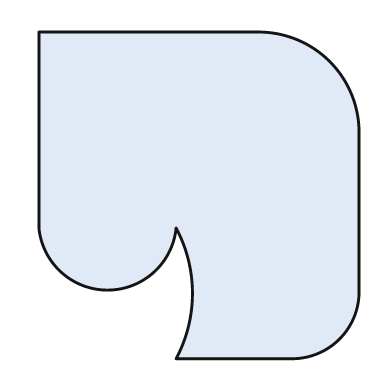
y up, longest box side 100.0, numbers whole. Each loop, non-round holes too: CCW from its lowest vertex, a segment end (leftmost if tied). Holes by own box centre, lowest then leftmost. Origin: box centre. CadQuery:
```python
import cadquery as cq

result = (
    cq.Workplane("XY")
    .moveTo(-7.0, -50.0)
    .lineTo(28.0, -50.0)
    .threePointArc((43.0, -44.0), (49.0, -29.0))
    .lineTo(49.0, 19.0)
    .threePointArc((40.0, 41.0), (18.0, 50.0))
    .lineTo(-49.0, 50.0)
    .lineTo(-49.0, -10.0)
    .threePointArc((-28.0, -29.0), (-7.0, -10.0))
    .threePointArc((-2.0, -30.0), (-7.0, -50.0))
    .close()
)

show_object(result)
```